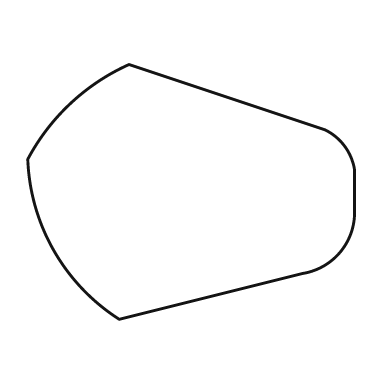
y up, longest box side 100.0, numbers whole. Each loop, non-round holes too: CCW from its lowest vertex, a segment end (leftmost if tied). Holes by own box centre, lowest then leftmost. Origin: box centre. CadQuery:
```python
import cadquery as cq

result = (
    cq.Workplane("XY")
    .moveTo(-22.0, -39.0)
    .lineTo(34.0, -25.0)
    .threePointArc((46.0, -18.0), (50.0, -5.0))
    .lineTo(50.0, 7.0)
    .threePointArc((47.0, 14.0), (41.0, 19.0))
    .lineTo(-19.0, 39.0)
    .threePointArc((-37.0, 27.0), (-50.0, 10.0))
    .threePointArc((-42.0, -18.0), (-22.0, -39.0))
    .close()
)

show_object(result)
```